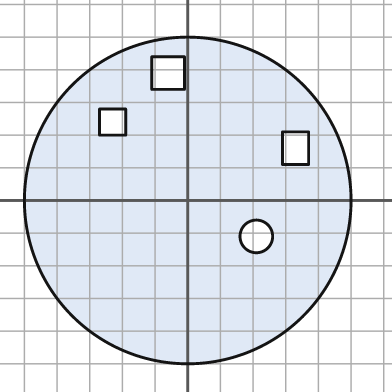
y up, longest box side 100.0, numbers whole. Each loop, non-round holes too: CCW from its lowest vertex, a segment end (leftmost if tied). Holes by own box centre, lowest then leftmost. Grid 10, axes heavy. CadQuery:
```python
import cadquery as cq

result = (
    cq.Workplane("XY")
    .moveTo(0.0, 0.0)
    .circle(50.0)
    .moveTo(21.0, -11.0)
    .circle(5.0)
    .moveTo(29.0, 11.0)
    .lineTo(37.0, 11.0)
    .lineTo(37.0, 21.0)
    .lineTo(29.0, 21.0)
    .close()
    .moveTo(-27.0, 20.0)
    .lineTo(-19.0, 20.0)
    .lineTo(-19.0, 28.0)
    .lineTo(-27.0, 28.0)
    .close()
    .moveTo(-11.0, 34.0)
    .lineTo(-1.0, 34.0)
    .lineTo(-1.0, 44.0)
    .lineTo(-11.0, 44.0)
    .close()
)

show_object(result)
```